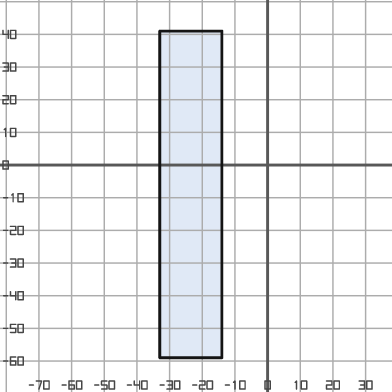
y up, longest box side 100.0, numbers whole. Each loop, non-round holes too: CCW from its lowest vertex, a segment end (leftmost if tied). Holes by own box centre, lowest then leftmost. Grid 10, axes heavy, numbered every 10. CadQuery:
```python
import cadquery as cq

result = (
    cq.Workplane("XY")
    .moveTo(-33.0, -59.0)
    .lineTo(-14.0, -59.0)
    .lineTo(-14.0, 41.0)
    .lineTo(-33.0, 41.0)
    .close()
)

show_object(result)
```